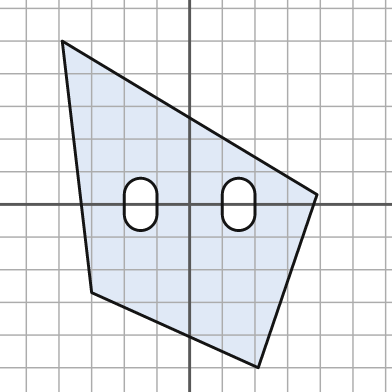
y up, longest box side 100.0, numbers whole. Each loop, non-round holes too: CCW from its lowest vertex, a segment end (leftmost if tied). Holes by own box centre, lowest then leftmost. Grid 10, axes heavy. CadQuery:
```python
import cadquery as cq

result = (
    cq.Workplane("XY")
    .moveTo(21.0, -50.0)
    .lineTo(39.0, 3.0)
    .lineTo(-39.0, 50.0)
    .lineTo(-30.0, -27.0)
    .close()
    .moveTo(-20.0, -3.0)
    .threePointArc((-15.0, -8.0), (-10.0, -3.0))
    .lineTo(-10.0, 3.0)
    .threePointArc((-15.0, 8.0), (-20.0, 3.0))
    .close()
    .moveTo(10.0, -3.0)
    .threePointArc((15.0, -8.0), (20.0, -3.0))
    .lineTo(20.0, 3.0)
    .threePointArc((15.0, 8.0), (10.0, 3.0))
    .close()
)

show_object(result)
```